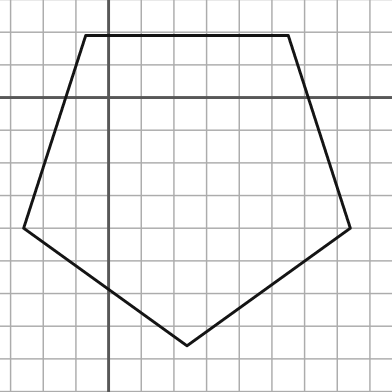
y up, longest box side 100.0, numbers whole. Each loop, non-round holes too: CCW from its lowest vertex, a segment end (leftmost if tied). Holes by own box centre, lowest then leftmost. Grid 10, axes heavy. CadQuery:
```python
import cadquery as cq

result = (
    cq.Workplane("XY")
    .moveTo(24.0, -76.0)
    .lineTo(74.0, -40.0)
    .lineTo(55.0, 19.0)
    .lineTo(-7.0, 19.0)
    .lineTo(-26.0, -40.0)
    .close()
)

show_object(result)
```